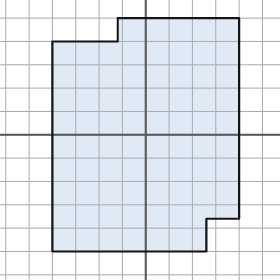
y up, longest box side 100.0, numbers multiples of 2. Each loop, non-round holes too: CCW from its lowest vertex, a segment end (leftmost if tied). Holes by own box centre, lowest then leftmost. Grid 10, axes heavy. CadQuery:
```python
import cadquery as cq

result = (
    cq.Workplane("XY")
    .moveTo(-40.0, -50.0)
    .lineTo(26.0, -50.0)
    .lineTo(26.0, -36.0)
    .lineTo(40.0, -36.0)
    .lineTo(40.0, 50.0)
    .lineTo(-12.0, 50.0)
    .lineTo(-12.0, 40.0)
    .lineTo(-40.0, 40.0)
    .close()
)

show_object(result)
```